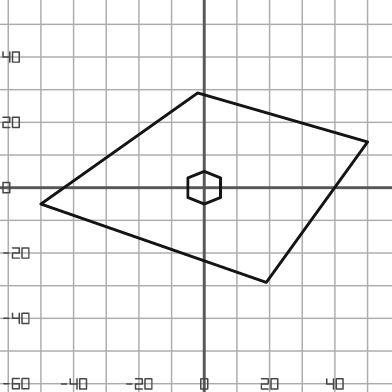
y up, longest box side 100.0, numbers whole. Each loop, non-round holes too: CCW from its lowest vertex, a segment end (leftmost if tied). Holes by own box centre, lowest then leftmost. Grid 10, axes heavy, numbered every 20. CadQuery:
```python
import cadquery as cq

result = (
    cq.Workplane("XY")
    .moveTo(19.0, -29.0)
    .lineTo(50.0, 14.0)
    .lineTo(-2.0, 29.0)
    .lineTo(-50.0, -5.0)
    .close()
    .moveTo(0.0, -5.0)
    .lineTo(5.0, -3.0)
    .lineTo(5.0, 3.0)
    .lineTo(0.0, 5.0)
    .lineTo(-5.0, 3.0)
    .lineTo(-5.0, -3.0)
    .close()
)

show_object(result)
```